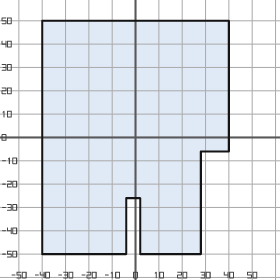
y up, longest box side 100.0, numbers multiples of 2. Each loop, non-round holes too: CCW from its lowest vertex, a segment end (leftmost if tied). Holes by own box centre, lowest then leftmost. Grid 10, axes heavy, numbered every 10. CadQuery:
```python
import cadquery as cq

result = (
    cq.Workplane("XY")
    .moveTo(-40.0, -50.0)
    .lineTo(-4.0, -50.0)
    .lineTo(-4.0, -26.0)
    .lineTo(2.0, -26.0)
    .lineTo(2.0, -50.0)
    .lineTo(28.0, -50.0)
    .lineTo(28.0, -6.0)
    .lineTo(40.0, -6.0)
    .lineTo(40.0, 50.0)
    .lineTo(-40.0, 50.0)
    .close()
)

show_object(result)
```